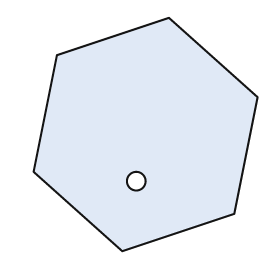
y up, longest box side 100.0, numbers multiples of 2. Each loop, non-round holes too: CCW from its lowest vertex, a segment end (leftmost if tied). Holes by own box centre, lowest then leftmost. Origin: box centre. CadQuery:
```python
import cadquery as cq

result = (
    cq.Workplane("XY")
    .moveTo(-10.0, -50.0)
    .lineTo(38.0, -34.0)
    .lineTo(48.0, 16.0)
    .lineTo(10.0, 50.0)
    .lineTo(-38.0, 34.0)
    .lineTo(-48.0, -16.0)
    .close()
    .moveTo(-4.0, -20.0)
    .circle(4.0)
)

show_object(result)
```